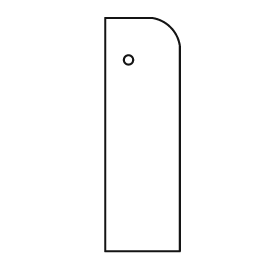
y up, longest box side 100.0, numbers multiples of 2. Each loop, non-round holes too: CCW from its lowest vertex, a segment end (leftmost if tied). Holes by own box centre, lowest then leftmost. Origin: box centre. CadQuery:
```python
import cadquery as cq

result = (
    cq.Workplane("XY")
    .moveTo(-16.0, -50.0)
    .lineTo(16.0, -50.0)
    .lineTo(16.0, 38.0)
    .threePointArc((12.0, 46.0), (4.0, 50.0))
    .lineTo(-16.0, 50.0)
    .close()
    .moveTo(-6.0, 32.0)
    .circle(2.0)
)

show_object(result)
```